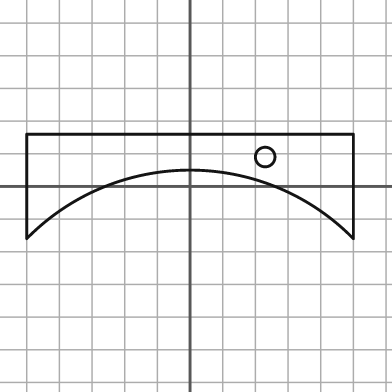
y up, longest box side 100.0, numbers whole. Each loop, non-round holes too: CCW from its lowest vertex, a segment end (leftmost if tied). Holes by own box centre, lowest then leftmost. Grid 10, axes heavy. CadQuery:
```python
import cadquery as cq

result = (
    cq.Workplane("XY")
    .moveTo(-50.0, -16.0)
    .threePointArc((0.0, 5.0), (50.0, -16.0))
    .lineTo(50.0, 16.0)
    .lineTo(-50.0, 16.0)
    .close()
    .moveTo(23.0, 9.0)
    .circle(3.0)
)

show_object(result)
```